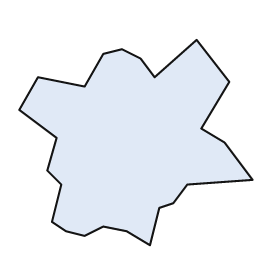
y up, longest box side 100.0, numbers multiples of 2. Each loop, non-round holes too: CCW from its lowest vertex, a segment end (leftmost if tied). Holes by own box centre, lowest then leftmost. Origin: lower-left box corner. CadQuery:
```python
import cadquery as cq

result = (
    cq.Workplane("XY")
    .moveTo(56.0, 0.0)
    .lineTo(60.0, 16.0)
    .lineTo(66.0, 18.0)
    .lineTo(72.0, 26.0)
    .lineTo(100.0, 28.0)
    .lineTo(88.0, 44.0)
    .lineTo(78.0, 50.0)
    .lineTo(90.0, 70.0)
    .lineTo(76.0, 88.0)
    .lineTo(58.0, 72.0)
    .lineTo(52.0, 80.0)
    .lineTo(44.0, 84.0)
    .lineTo(36.0, 82.0)
    .lineTo(28.0, 68.0)
    .lineTo(8.0, 72.0)
    .lineTo(0.0, 58.0)
    .lineTo(16.0, 46.0)
    .lineTo(12.0, 32.0)
    .lineTo(18.0, 26.0)
    .lineTo(14.0, 10.0)
    .lineTo(20.0, 6.0)
    .lineTo(28.0, 4.0)
    .lineTo(36.0, 8.0)
    .lineTo(46.0, 6.0)
    .close()
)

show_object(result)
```